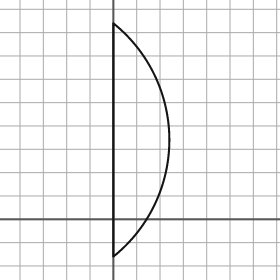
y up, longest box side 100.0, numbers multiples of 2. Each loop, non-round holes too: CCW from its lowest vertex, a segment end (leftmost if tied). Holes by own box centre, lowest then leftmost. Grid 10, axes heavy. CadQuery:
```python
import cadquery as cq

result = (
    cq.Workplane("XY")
    .moveTo(0.0, -16.0)
    .threePointArc((24.0, 34.0), (0.0, 84.0))
    .close()
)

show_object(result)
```